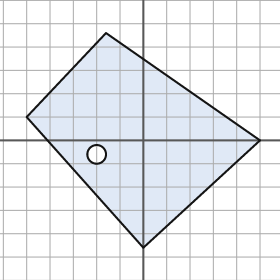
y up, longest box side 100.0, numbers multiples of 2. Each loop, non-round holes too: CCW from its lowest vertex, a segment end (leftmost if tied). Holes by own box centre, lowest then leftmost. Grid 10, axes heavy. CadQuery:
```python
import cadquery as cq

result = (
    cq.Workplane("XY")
    .moveTo(0.0, -46.0)
    .lineTo(50.0, 0.0)
    .lineTo(-16.0, 46.0)
    .lineTo(-50.0, 10.0)
    .close()
    .moveTo(-20.0, -6.0)
    .circle(4.0)
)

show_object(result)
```